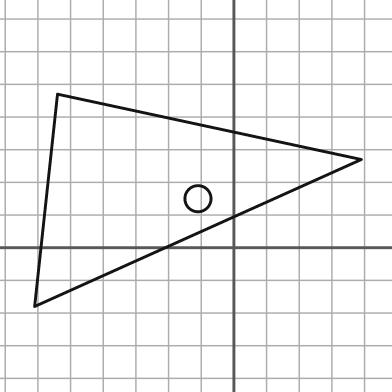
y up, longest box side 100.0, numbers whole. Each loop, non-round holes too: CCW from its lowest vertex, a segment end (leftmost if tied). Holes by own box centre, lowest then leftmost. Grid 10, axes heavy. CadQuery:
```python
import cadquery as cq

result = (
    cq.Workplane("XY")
    .moveTo(-61.0, -18.0)
    .lineTo(39.0, 27.0)
    .lineTo(-54.0, 47.0)
    .close()
    .moveTo(-11.0, 15.0)
    .circle(4.0)
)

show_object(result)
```